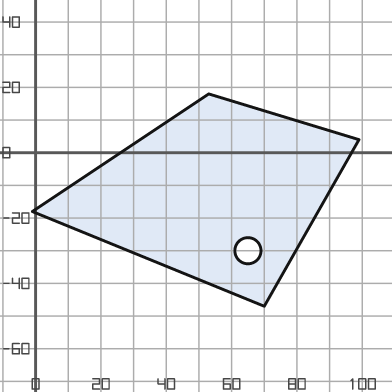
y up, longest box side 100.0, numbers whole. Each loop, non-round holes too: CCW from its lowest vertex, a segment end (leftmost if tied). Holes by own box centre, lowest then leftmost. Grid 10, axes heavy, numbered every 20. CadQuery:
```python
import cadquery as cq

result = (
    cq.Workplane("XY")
    .moveTo(70.0, -47.0)
    .lineTo(99.0, 4.0)
    .lineTo(53.0, 18.0)
    .lineTo(-1.0, -18.0)
    .close()
    .moveTo(65.0, -30.0)
    .circle(4.0)
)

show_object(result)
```